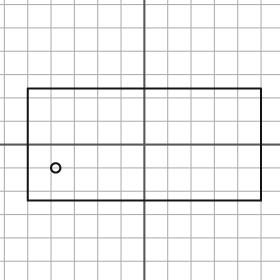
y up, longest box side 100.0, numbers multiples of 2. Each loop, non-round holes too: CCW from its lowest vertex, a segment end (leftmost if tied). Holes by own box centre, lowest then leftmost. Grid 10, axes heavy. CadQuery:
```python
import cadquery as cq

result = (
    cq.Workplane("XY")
    .moveTo(-50.0, -24.0)
    .lineTo(50.0, -24.0)
    .lineTo(50.0, 24.0)
    .lineTo(-50.0, 24.0)
    .close()
    .moveTo(-38.0, -10.0)
    .circle(2.0)
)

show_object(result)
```